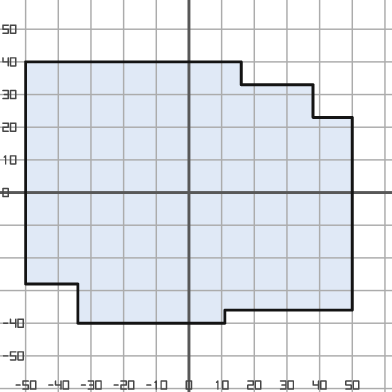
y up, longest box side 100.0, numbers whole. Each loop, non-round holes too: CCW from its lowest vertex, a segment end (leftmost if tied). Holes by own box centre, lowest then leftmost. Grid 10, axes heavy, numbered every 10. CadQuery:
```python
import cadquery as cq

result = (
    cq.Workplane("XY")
    .moveTo(-34.0, -40.0)
    .lineTo(11.0, -40.0)
    .lineTo(11.0, -36.0)
    .lineTo(50.0, -36.0)
    .lineTo(50.0, 23.0)
    .lineTo(38.0, 23.0)
    .lineTo(38.0, 33.0)
    .lineTo(16.0, 33.0)
    .lineTo(16.0, 40.0)
    .lineTo(-50.0, 40.0)
    .lineTo(-50.0, -28.0)
    .lineTo(-34.0, -28.0)
    .close()
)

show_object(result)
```